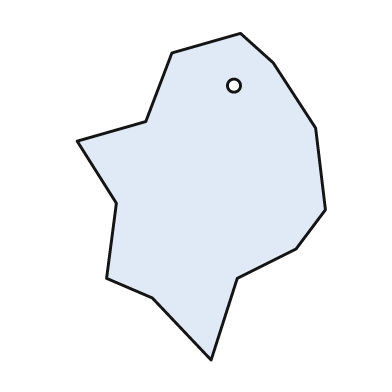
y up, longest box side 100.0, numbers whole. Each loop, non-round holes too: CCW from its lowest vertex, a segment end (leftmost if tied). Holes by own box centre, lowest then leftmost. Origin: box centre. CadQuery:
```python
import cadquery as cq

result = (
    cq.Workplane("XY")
    .moveTo(3.0, -50.0)
    .lineTo(11.0, -25.0)
    .lineTo(29.0, -16.0)
    .lineTo(38.0, -4.0)
    .lineTo(35.0, 21.0)
    .lineTo(22.0, 41.0)
    .lineTo(12.0, 50.0)
    .lineTo(-9.0, 44.0)
    .lineTo(-17.0, 23.0)
    .lineTo(-38.0, 17.0)
    .lineTo(-26.0, -2.0)
    .lineTo(-29.0, -25.0)
    .lineTo(-15.0, -31.0)
    .close()
    .moveTo(10.0, 34.0)
    .circle(2.0)
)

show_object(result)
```